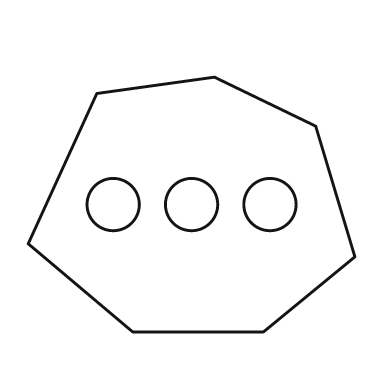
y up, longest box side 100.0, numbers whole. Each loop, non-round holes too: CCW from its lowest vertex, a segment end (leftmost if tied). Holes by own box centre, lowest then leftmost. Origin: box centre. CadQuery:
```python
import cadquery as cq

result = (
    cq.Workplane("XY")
    .moveTo(-18.0, -39.0)
    .lineTo(22.0, -39.0)
    .lineTo(50.0, -16.0)
    .lineTo(38.0, 24.0)
    .lineTo(7.0, 39.0)
    .lineTo(-29.0, 34.0)
    .lineTo(-50.0, -12.0)
    .close()
    .moveTo(-24.0, 0.0)
    .circle(8.0)
    .moveTo(0.0, 0.0)
    .circle(8.0)
    .moveTo(24.0, 0.0)
    .circle(8.0)
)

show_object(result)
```